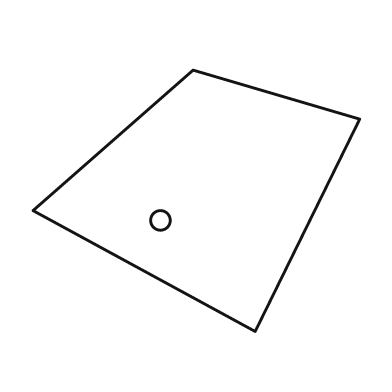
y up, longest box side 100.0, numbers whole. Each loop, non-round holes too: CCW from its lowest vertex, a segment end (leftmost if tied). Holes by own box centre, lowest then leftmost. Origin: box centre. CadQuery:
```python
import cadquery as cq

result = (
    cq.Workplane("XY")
    .moveTo(18.0, -40.0)
    .lineTo(50.0, 25.0)
    .lineTo(-1.0, 40.0)
    .lineTo(-50.0, -3.0)
    .close()
    .moveTo(-11.0, -6.0)
    .circle(3.0)
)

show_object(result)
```